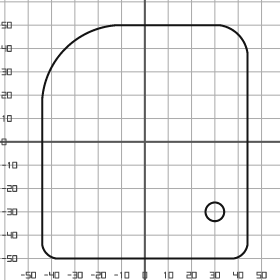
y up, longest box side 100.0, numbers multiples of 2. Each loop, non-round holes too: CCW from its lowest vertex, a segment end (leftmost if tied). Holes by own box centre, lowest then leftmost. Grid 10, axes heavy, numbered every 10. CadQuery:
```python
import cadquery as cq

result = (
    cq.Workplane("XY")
    .moveTo(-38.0, -50.0)
    .lineTo(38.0, -50.0)
    .threePointArc((42.0, -48.0), (44.0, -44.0))
    .lineTo(44.0, 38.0)
    .threePointArc((40.0, 46.0), (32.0, 50.0))
    .lineTo(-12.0, 50.0)
    .threePointArc((-34.0, 40.0), (-44.0, 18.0))
    .lineTo(-44.0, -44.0)
    .threePointArc((-42.0, -48.0), (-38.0, -50.0))
    .close()
    .moveTo(30.0, -30.0)
    .circle(4.0)
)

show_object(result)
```